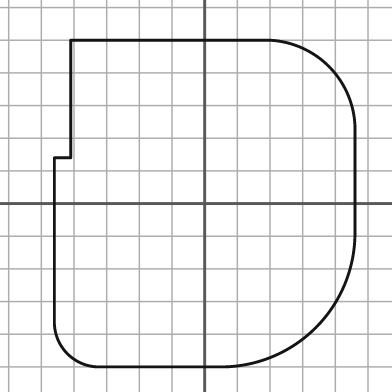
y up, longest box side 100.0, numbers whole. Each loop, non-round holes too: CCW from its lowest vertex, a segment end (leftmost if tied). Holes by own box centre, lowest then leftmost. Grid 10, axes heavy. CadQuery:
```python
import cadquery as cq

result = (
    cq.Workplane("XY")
    .moveTo(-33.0, -50.0)
    .lineTo(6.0, -50.0)
    .threePointArc((34.0, -38.0), (46.0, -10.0))
    .lineTo(46.0, 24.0)
    .threePointArc((38.0, 42.0), (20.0, 50.0))
    .lineTo(-41.0, 50.0)
    .lineTo(-41.0, 14.0)
    .lineTo(-46.0, 14.0)
    .lineTo(-46.0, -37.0)
    .threePointArc((-42.0, -46.0), (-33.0, -50.0))
    .close()
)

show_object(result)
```